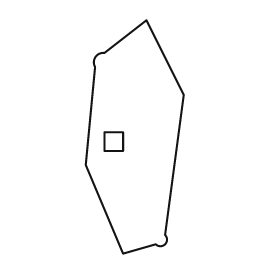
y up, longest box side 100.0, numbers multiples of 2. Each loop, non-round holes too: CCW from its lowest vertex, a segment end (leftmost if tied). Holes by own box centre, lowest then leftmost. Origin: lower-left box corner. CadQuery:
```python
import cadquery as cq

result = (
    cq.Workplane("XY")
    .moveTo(16.0, 0.0)
    .lineTo(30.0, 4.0)
    .threePointArc((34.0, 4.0), (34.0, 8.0))
    .lineTo(42.0, 68.0)
    .lineTo(26.0, 100.0)
    .lineTo(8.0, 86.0)
    .threePointArc((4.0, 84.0), (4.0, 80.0))
    .lineTo(0.0, 38.0)
    .close()
    .moveTo(8.0, 44.0)
    .lineTo(16.0, 44.0)
    .lineTo(16.0, 52.0)
    .lineTo(8.0, 52.0)
    .close()
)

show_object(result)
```